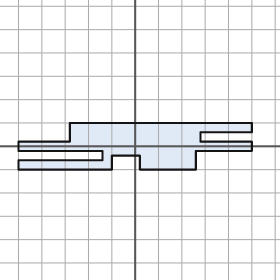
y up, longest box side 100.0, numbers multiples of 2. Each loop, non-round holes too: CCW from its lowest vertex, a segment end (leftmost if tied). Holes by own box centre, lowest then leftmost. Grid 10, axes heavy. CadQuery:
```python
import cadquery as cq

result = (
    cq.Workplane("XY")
    .moveTo(-50.0, -10.0)
    .lineTo(-10.0, -10.0)
    .lineTo(-10.0, -4.0)
    .lineTo(2.0, -4.0)
    .lineTo(2.0, -10.0)
    .lineTo(26.0, -10.0)
    .lineTo(26.0, -2.0)
    .lineTo(50.0, -2.0)
    .lineTo(50.0, 2.0)
    .lineTo(28.0, 2.0)
    .lineTo(28.0, 6.0)
    .lineTo(50.0, 6.0)
    .lineTo(50.0, 10.0)
    .lineTo(-28.0, 10.0)
    .lineTo(-28.0, 2.0)
    .lineTo(-50.0, 2.0)
    .lineTo(-50.0, -2.0)
    .lineTo(-14.0, -2.0)
    .lineTo(-14.0, -6.0)
    .lineTo(-50.0, -6.0)
    .close()
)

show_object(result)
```